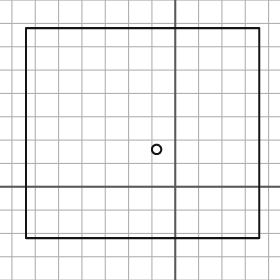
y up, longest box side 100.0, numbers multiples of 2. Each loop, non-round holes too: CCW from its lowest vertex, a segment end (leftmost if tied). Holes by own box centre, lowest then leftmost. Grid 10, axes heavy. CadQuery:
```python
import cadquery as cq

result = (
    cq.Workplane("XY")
    .moveTo(-64.0, -22.0)
    .lineTo(36.0, -22.0)
    .lineTo(36.0, 68.0)
    .lineTo(-64.0, 68.0)
    .close()
    .moveTo(-8.0, 16.0)
    .circle(2.0)
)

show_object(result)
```